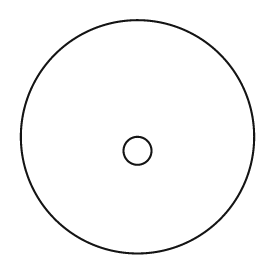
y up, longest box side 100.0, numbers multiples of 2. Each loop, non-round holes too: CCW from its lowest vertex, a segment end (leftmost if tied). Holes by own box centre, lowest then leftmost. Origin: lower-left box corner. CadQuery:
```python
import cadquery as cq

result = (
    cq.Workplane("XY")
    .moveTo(50.0, 50.0)
    .circle(50.0)
    .moveTo(50.0, 44.0)
    .circle(6.0)
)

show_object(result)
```